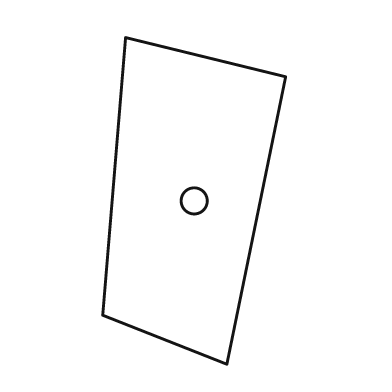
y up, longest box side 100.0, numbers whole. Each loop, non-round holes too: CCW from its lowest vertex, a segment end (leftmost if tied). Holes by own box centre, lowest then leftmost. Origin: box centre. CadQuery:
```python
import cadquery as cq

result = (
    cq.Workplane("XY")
    .moveTo(10.0, -50.0)
    .lineTo(28.0, 38.0)
    .lineTo(-21.0, 50.0)
    .lineTo(-28.0, -35.0)
    .close()
    .moveTo(0.0, 0.0)
    .circle(4.0)
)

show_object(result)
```